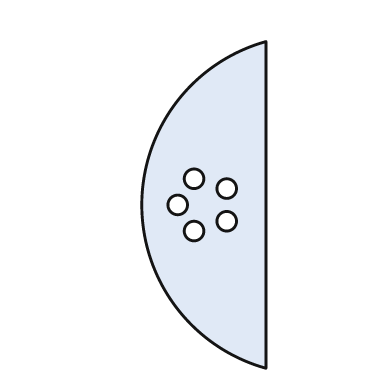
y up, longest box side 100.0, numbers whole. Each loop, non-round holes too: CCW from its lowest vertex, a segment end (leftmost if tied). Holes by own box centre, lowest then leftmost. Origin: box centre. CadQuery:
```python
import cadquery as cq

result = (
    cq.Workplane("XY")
    .moveTo(19.0, -50.0)
    .lineTo(19.0, 50.0)
    .threePointArc((-19.0, 0.0), (19.0, -50.0))
    .close()
    .moveTo(-3.0, -8.0)
    .circle(3.0)
    .moveTo(7.0, -5.0)
    .circle(3.0)
    .moveTo(-8.0, 0.0)
    .circle(3.0)
    .moveTo(7.0, 5.0)
    .circle(3.0)
    .moveTo(-3.0, 8.0)
    .circle(3.0)
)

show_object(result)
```